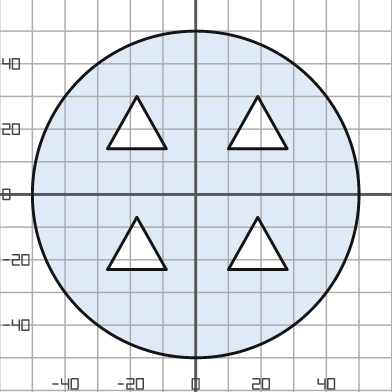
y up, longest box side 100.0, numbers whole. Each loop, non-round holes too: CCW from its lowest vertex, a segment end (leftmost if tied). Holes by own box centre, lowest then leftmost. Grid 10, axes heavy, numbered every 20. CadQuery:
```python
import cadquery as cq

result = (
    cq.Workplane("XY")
    .moveTo(0.0, 0.0)
    .circle(50.0)
    .moveTo(-27.0, -23.0)
    .lineTo(-9.0, -23.0)
    .lineTo(-18.0, -7.0)
    .close()
    .moveTo(10.0, -23.0)
    .lineTo(28.0, -23.0)
    .lineTo(19.0, -7.0)
    .close()
    .moveTo(-27.0, 14.0)
    .lineTo(-9.0, 14.0)
    .lineTo(-18.0, 30.0)
    .close()
    .moveTo(10.0, 14.0)
    .lineTo(28.0, 14.0)
    .lineTo(19.0, 30.0)
    .close()
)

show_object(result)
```